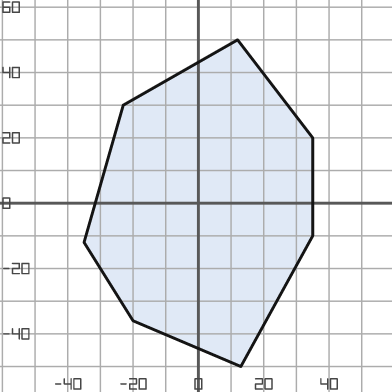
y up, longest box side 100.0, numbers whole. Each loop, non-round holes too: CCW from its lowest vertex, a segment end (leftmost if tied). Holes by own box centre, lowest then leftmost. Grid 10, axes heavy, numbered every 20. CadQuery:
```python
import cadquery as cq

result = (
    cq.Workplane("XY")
    .moveTo(13.0, -50.0)
    .lineTo(35.0, -10.0)
    .lineTo(35.0, 20.0)
    .lineTo(12.0, 50.0)
    .lineTo(-23.0, 30.0)
    .lineTo(-35.0, -12.0)
    .lineTo(-20.0, -36.0)
    .close()
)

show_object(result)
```